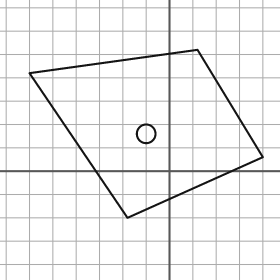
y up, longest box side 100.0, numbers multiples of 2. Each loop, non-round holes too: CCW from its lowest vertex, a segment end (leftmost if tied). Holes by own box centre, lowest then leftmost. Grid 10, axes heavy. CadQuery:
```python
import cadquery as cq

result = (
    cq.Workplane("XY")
    .moveTo(-18.0, -20.0)
    .lineTo(40.0, 6.0)
    .lineTo(12.0, 52.0)
    .lineTo(-60.0, 42.0)
    .close()
    .moveTo(-10.0, 16.0)
    .circle(4.0)
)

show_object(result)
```